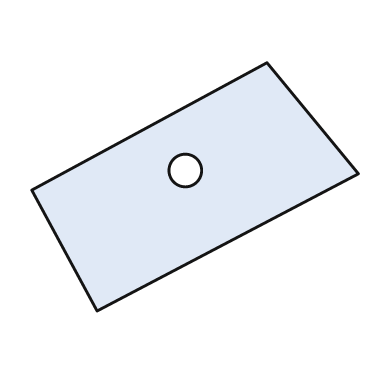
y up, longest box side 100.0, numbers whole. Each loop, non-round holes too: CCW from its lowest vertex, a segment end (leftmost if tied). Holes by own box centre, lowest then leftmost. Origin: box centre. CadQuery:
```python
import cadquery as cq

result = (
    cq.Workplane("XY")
    .moveTo(-30.0, -38.0)
    .lineTo(50.0, 4.0)
    .lineTo(22.0, 38.0)
    .lineTo(-50.0, -1.0)
    .close()
    .moveTo(-3.0, 5.0)
    .circle(5.0)
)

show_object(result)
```